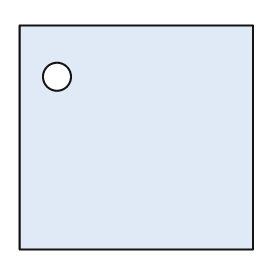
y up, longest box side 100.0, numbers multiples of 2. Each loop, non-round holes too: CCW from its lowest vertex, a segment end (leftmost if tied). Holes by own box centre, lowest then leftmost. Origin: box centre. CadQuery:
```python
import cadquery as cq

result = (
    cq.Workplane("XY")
    .moveTo(-50.0, -48.0)
    .lineTo(50.0, -48.0)
    .lineTo(50.0, 48.0)
    .lineTo(-50.0, 48.0)
    .close()
    .moveTo(-34.0, 26.0)
    .circle(6.0)
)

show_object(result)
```